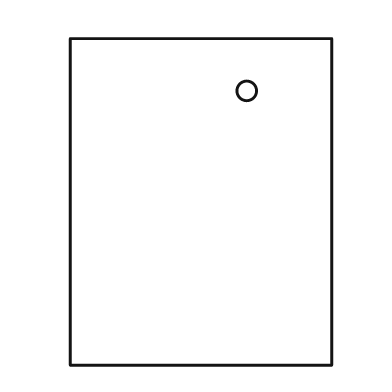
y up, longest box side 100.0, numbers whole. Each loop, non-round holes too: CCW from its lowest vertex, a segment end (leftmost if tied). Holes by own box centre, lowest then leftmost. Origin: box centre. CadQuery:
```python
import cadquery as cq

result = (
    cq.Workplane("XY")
    .moveTo(-40.0, -50.0)
    .lineTo(40.0, -50.0)
    .lineTo(40.0, 50.0)
    .lineTo(-40.0, 50.0)
    .close()
    .moveTo(14.0, 34.0)
    .circle(3.0)
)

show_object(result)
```